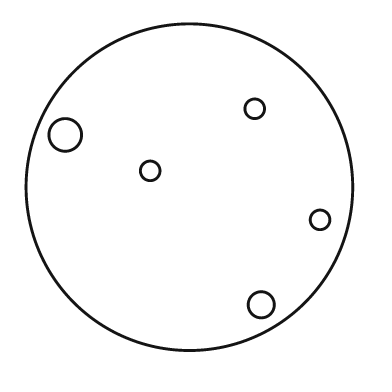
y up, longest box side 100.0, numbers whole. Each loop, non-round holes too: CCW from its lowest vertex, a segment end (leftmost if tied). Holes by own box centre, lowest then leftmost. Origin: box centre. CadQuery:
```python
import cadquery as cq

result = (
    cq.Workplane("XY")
    .moveTo(0.0, 0.0)
    .circle(50.0)
    .moveTo(22.0, -36.0)
    .circle(4.0)
    .moveTo(40.0, -10.0)
    .circle(3.0)
    .moveTo(-12.0, 5.0)
    .circle(3.0)
    .moveTo(-38.0, 16.0)
    .circle(5.0)
    .moveTo(20.0, 24.0)
    .circle(3.0)
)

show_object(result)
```